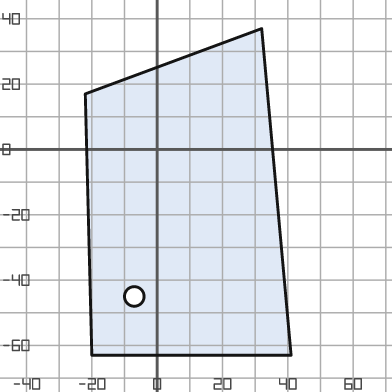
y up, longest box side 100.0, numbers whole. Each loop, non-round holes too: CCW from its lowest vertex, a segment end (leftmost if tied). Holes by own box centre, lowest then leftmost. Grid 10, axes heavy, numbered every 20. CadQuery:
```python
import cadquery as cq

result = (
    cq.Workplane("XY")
    .moveTo(-20.0, -63.0)
    .lineTo(41.0, -63.0)
    .lineTo(32.0, 37.0)
    .lineTo(-22.0, 17.0)
    .close()
    .moveTo(-7.0, -45.0)
    .circle(3.0)
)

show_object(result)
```